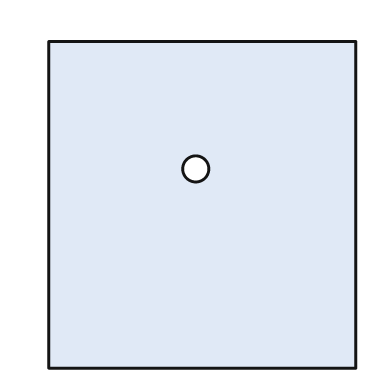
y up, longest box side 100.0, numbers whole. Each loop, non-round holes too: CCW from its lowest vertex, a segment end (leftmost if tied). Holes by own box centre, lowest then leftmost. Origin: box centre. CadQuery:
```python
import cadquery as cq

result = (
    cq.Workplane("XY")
    .moveTo(-47.0, -50.0)
    .lineTo(47.0, -50.0)
    .lineTo(47.0, 50.0)
    .lineTo(-47.0, 50.0)
    .close()
    .moveTo(-2.0, 11.0)
    .circle(4.0)
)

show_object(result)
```